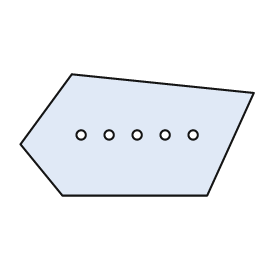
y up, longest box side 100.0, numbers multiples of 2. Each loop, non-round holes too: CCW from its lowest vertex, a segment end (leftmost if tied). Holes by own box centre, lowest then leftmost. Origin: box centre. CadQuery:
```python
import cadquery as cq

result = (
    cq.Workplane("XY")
    .moveTo(-32.0, -26.0)
    .lineTo(30.0, -26.0)
    .lineTo(50.0, 18.0)
    .lineTo(-28.0, 26.0)
    .lineTo(-50.0, -4.0)
    .close()
    .moveTo(-24.0, 0.0)
    .circle(2.0)
    .moveTo(-12.0, 0.0)
    .circle(2.0)
    .moveTo(0.0, 0.0)
    .circle(2.0)
    .moveTo(12.0, 0.0)
    .circle(2.0)
    .moveTo(24.0, 0.0)
    .circle(2.0)
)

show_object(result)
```